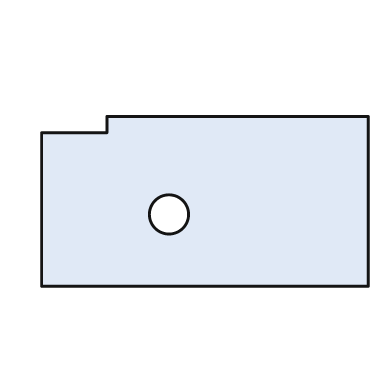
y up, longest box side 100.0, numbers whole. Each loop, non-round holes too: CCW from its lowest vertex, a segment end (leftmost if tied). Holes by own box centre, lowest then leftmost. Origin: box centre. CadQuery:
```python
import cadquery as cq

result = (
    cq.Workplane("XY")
    .moveTo(-50.0, -26.0)
    .lineTo(50.0, -26.0)
    .lineTo(50.0, 26.0)
    .lineTo(-30.0, 26.0)
    .lineTo(-30.0, 21.0)
    .lineTo(-50.0, 21.0)
    .close()
    .moveTo(-11.0, -4.0)
    .circle(6.0)
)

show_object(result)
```